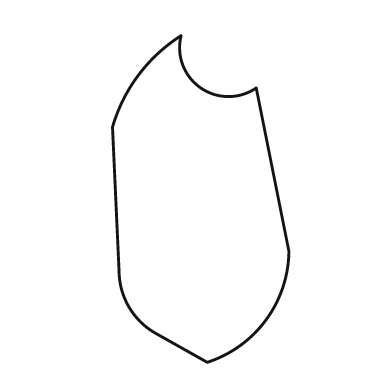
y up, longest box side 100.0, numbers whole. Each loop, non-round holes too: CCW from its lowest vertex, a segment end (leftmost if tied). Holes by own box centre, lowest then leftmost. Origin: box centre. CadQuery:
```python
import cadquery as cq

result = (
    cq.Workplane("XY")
    .moveTo(2.0, -50.0)
    .threePointArc((20.0, -37.0), (27.0, -16.0))
    .lineTo(17.0, 34.0)
    .threePointArc((0.0, 34.0), (-6.0, 50.0))
    .threePointArc((-19.0, 38.0), (-27.0, 22.0))
    .lineTo(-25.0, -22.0)
    .threePointArc((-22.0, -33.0), (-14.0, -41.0))
    .close()
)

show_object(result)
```